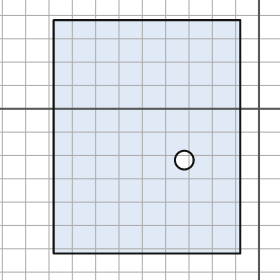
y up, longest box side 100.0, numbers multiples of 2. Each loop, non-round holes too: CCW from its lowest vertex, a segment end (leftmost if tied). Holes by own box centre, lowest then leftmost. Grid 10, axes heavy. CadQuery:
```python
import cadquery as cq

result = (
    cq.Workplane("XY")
    .moveTo(-88.0, -62.0)
    .lineTo(-8.0, -62.0)
    .lineTo(-8.0, 38.0)
    .lineTo(-88.0, 38.0)
    .close()
    .moveTo(-32.0, -22.0)
    .circle(4.0)
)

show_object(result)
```